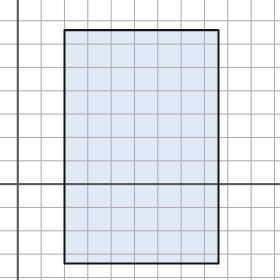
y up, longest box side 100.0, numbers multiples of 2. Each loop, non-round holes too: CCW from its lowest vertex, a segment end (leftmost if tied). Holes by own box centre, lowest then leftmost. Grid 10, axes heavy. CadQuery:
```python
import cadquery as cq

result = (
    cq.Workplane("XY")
    .moveTo(20.0, -34.0)
    .lineTo(86.0, -34.0)
    .lineTo(86.0, 66.0)
    .lineTo(20.0, 66.0)
    .close()
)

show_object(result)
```